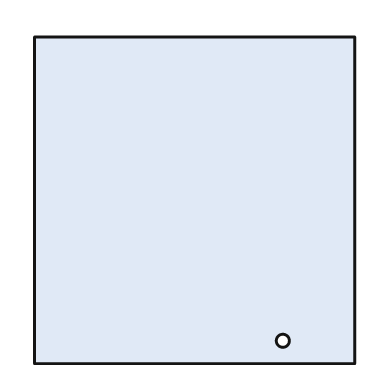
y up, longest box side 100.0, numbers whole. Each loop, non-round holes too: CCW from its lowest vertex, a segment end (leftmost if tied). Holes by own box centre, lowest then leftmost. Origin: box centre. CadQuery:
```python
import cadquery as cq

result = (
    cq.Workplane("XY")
    .moveTo(-49.0, -50.0)
    .lineTo(49.0, -50.0)
    .lineTo(49.0, 50.0)
    .lineTo(-49.0, 50.0)
    .close()
    .moveTo(27.0, -43.0)
    .circle(2.0)
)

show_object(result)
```